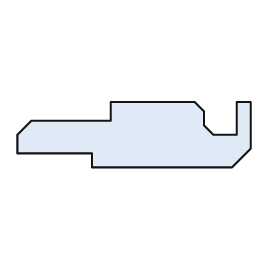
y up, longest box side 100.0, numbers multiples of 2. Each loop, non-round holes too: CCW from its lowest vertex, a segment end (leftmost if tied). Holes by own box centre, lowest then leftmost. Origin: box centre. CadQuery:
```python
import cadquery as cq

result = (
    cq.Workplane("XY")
    .moveTo(-18.0, -14.0)
    .lineTo(42.0, -14.0)
    .lineTo(50.0, -6.0)
    .lineTo(50.0, 14.0)
    .lineTo(44.0, 14.0)
    .lineTo(44.0, 0.0)
    .lineTo(34.0, 0.0)
    .lineTo(30.0, 4.0)
    .lineTo(30.0, 10.0)
    .lineTo(26.0, 14.0)
    .lineTo(-10.0, 14.0)
    .lineTo(-10.0, 6.0)
    .lineTo(-44.0, 6.0)
    .lineTo(-50.0, 0.0)
    .lineTo(-50.0, -8.0)
    .lineTo(-18.0, -8.0)
    .close()
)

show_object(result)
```